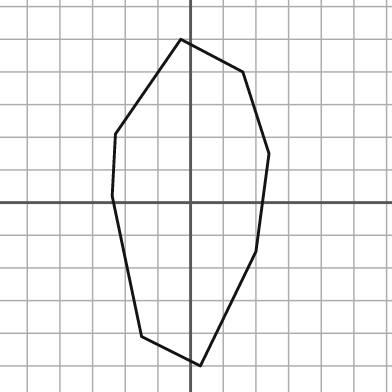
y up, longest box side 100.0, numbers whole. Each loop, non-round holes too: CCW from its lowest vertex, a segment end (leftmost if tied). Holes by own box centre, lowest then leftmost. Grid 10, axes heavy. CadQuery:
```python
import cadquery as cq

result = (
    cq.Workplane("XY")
    .moveTo(3.0, -50.0)
    .lineTo(20.0, -15.0)
    .lineTo(24.0, 15.0)
    .lineTo(16.0, 40.0)
    .lineTo(-3.0, 50.0)
    .lineTo(-23.0, 21.0)
    .lineTo(-24.0, 2.0)
    .lineTo(-15.0, -41.0)
    .close()
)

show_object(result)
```